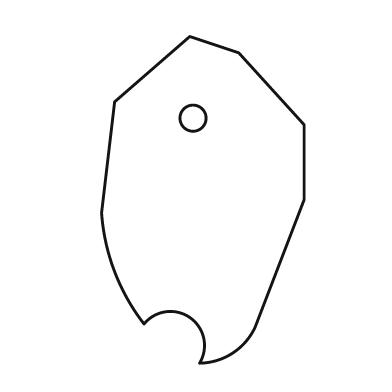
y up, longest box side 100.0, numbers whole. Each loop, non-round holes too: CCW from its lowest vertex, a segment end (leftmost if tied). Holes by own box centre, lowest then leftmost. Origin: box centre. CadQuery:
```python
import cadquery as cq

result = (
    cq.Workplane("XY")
    .moveTo(-1.0, -50.0)
    .threePointArc((9.0, -47.0), (16.0, -39.0))
    .lineTo(31.0, 0.0)
    .lineTo(31.0, 23.0)
    .lineTo(11.0, 45.0)
    .lineTo(-4.0, 50.0)
    .lineTo(-27.0, 30.0)
    .lineTo(-31.0, -4.0)
    .threePointArc((-27.0, -22.0), (-18.0, -38.0))
    .threePointArc((-4.0, -36.0), (-1.0, -50.0))
    .close()
    .moveTo(-3.0, 25.0)
    .circle(4.0)
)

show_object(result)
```